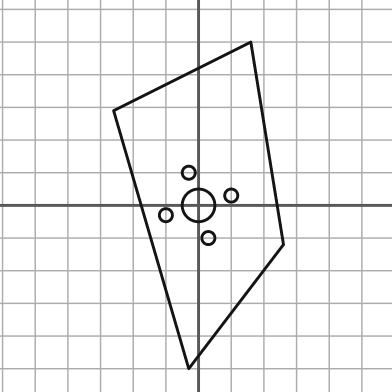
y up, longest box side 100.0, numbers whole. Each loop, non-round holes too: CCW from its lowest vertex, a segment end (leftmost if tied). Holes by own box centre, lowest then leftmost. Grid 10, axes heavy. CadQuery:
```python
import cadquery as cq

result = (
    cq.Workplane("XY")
    .moveTo(-3.0, -50.0)
    .lineTo(26.0, -12.0)
    .lineTo(16.0, 50.0)
    .lineTo(-26.0, 29.0)
    .close()
    .moveTo(3.0, -10.0)
    .circle(2.0)
    .moveTo(-10.0, -3.0)
    .circle(2.0)
    .moveTo(0.0, 0.0)
    .circle(5.0)
    .moveTo(10.0, 3.0)
    .circle(2.0)
    .moveTo(-3.0, 10.0)
    .circle(2.0)
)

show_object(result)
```